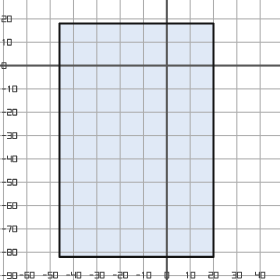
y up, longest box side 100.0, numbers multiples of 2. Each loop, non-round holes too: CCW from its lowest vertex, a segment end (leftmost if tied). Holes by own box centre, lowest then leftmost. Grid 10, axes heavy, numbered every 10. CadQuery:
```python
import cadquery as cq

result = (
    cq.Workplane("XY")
    .moveTo(-46.0, -82.0)
    .lineTo(20.0, -82.0)
    .lineTo(20.0, 18.0)
    .lineTo(-46.0, 18.0)
    .close()
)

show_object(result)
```